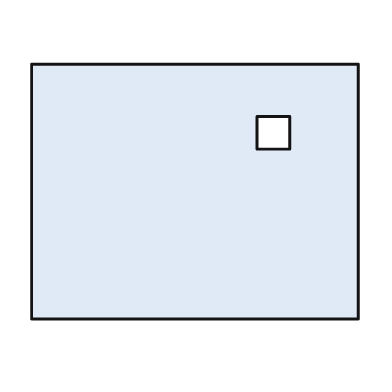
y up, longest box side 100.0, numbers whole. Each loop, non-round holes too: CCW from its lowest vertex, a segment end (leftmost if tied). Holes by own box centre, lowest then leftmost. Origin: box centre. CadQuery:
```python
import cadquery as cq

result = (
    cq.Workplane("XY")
    .moveTo(-50.0, -39.0)
    .lineTo(50.0, -39.0)
    .lineTo(50.0, 39.0)
    .lineTo(-50.0, 39.0)
    .close()
    .moveTo(19.0, 13.0)
    .lineTo(29.0, 13.0)
    .lineTo(29.0, 23.0)
    .lineTo(19.0, 23.0)
    .close()
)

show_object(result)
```